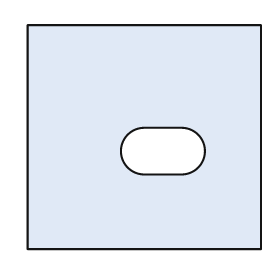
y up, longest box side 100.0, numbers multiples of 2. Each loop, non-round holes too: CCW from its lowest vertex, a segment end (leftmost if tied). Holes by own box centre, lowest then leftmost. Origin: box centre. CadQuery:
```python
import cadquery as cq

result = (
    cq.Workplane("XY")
    .moveTo(-50.0, -48.0)
    .lineTo(50.0, -48.0)
    .lineTo(50.0, 48.0)
    .lineTo(-50.0, 48.0)
    .close()
    .moveTo(0.0, -16.0)
    .lineTo(16.0, -16.0)
    .threePointArc((26.0, -6.0), (16.0, 4.0))
    .lineTo(0.0, 4.0)
    .threePointArc((-10.0, -6.0), (0.0, -16.0))
    .close()
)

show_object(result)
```